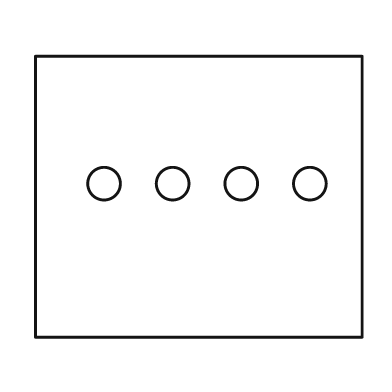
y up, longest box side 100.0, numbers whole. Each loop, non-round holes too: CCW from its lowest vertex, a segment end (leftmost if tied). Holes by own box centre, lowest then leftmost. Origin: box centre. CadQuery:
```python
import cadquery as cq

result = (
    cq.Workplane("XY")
    .moveTo(-50.0, -43.0)
    .lineTo(50.0, -43.0)
    .lineTo(50.0, 43.0)
    .lineTo(-50.0, 43.0)
    .close()
    .moveTo(-29.0, 4.0)
    .circle(5.0)
    .moveTo(-8.0, 4.0)
    .circle(5.0)
    .moveTo(13.0, 4.0)
    .circle(5.0)
    .moveTo(34.0, 4.0)
    .circle(5.0)
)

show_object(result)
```